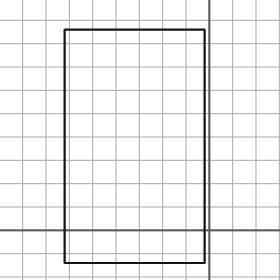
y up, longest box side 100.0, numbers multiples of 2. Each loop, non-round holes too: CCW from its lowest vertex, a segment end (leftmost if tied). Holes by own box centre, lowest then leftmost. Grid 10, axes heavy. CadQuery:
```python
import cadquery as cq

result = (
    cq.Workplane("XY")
    .moveTo(-62.0, -14.0)
    .lineTo(-2.0, -14.0)
    .lineTo(-2.0, 86.0)
    .lineTo(-62.0, 86.0)
    .close()
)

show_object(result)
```